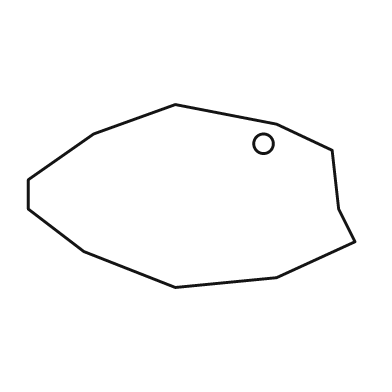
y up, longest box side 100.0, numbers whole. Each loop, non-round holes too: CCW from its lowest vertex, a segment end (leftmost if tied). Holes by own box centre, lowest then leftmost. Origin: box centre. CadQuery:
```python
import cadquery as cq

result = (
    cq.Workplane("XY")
    .moveTo(-5.0, -28.0)
    .lineTo(26.0, -25.0)
    .lineTo(50.0, -14.0)
    .lineTo(45.0, -4.0)
    .lineTo(43.0, 14.0)
    .lineTo(26.0, 22.0)
    .lineTo(-5.0, 28.0)
    .lineTo(-30.0, 19.0)
    .lineTo(-50.0, 5.0)
    .lineTo(-50.0, -4.0)
    .lineTo(-33.0, -17.0)
    .close()
    .moveTo(22.0, 16.0)
    .circle(3.0)
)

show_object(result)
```